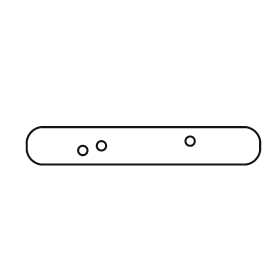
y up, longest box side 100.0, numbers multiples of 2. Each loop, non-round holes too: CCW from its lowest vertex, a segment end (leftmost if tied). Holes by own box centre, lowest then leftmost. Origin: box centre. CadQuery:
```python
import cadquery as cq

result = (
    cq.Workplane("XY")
    .moveTo(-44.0, -8.0)
    .lineTo(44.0, -8.0)
    .threePointArc((48.0, -6.0), (50.0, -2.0))
    .lineTo(50.0, 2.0)
    .threePointArc((48.0, 6.0), (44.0, 8.0))
    .lineTo(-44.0, 8.0)
    .threePointArc((-48.0, 6.0), (-50.0, 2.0))
    .lineTo(-50.0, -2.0)
    .threePointArc((-48.0, -6.0), (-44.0, -8.0))
    .close()
    .moveTo(-26.0, -2.0)
    .circle(2.0)
    .moveTo(-18.0, 0.0)
    .circle(2.0)
    .moveTo(20.0, 2.0)
    .circle(2.0)
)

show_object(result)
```